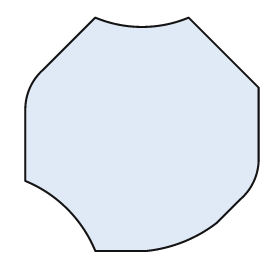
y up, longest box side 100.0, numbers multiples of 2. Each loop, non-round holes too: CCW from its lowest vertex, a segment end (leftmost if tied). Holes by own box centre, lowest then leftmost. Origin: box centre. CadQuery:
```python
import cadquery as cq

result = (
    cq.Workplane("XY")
    .moveTo(-20.0, -50.0)
    .lineTo(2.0, -50.0)
    .threePointArc((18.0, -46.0), (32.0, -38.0))
    .lineTo(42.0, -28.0)
    .threePointArc((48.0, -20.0), (50.0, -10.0))
    .lineTo(50.0, 20.0)
    .lineTo(20.0, 50.0)
    .threePointArc((0.0, 46.0), (-20.0, 50.0))
    .lineTo(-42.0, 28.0)
    .threePointArc((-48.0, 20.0), (-50.0, 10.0))
    .lineTo(-50.0, -20.0)
    .threePointArc((-32.0, -32.0), (-20.0, -50.0))
    .close()
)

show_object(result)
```